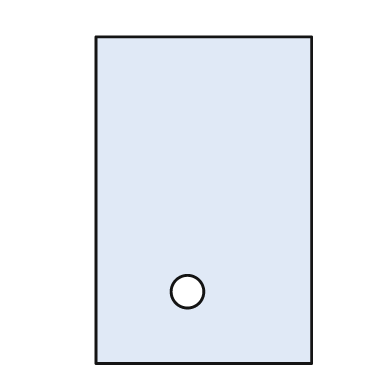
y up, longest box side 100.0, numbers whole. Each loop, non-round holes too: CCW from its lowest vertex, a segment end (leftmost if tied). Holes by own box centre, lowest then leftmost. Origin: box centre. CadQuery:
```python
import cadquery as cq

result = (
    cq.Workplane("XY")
    .moveTo(-33.0, -50.0)
    .lineTo(33.0, -50.0)
    .lineTo(33.0, 50.0)
    .lineTo(-33.0, 50.0)
    .close()
    .moveTo(-5.0, -28.0)
    .circle(5.0)
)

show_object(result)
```